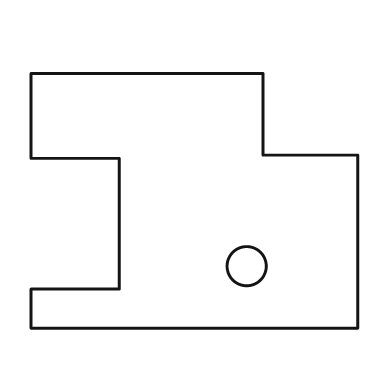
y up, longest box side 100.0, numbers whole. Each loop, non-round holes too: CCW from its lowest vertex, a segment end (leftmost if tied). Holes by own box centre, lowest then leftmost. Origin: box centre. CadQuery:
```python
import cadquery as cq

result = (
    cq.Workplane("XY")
    .moveTo(-50.0, -39.0)
    .lineTo(50.0, -39.0)
    .lineTo(50.0, 14.0)
    .lineTo(21.0, 14.0)
    .lineTo(21.0, 39.0)
    .lineTo(-50.0, 39.0)
    .lineTo(-50.0, 13.0)
    .lineTo(-23.0, 13.0)
    .lineTo(-23.0, -27.0)
    .lineTo(-50.0, -27.0)
    .close()
    .moveTo(16.0, -20.0)
    .circle(6.0)
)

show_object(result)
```